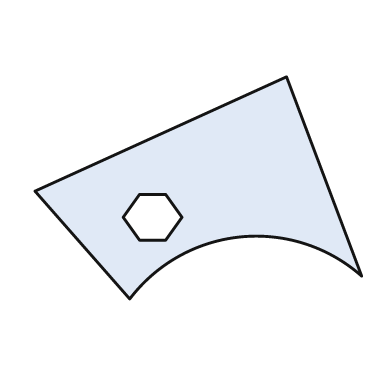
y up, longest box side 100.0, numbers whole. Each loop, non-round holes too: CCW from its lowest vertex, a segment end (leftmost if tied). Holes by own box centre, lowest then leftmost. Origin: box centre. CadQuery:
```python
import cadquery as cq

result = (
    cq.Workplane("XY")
    .moveTo(-21.0, -34.0)
    .threePointArc((13.0, -15.0), (50.0, -27.0))
    .lineTo(27.0, 34.0)
    .lineTo(-50.0, -1.0)
    .close()
    .moveTo(-18.0, -16.0)
    .lineTo(-10.0, -16.0)
    .lineTo(-5.0, -9.0)
    .lineTo(-10.0, -2.0)
    .lineTo(-18.0, -2.0)
    .lineTo(-23.0, -9.0)
    .close()
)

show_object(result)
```